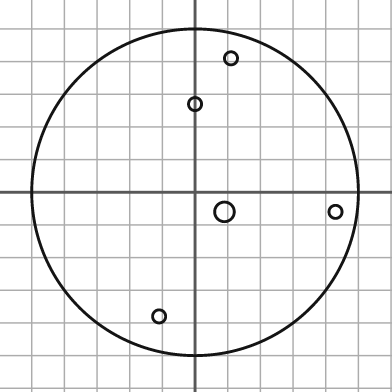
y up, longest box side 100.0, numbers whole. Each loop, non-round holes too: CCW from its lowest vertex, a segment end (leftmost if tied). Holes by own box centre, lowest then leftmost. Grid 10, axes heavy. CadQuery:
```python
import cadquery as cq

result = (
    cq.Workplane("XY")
    .moveTo(0.0, 0.0)
    .circle(50.0)
    .moveTo(-11.0, -38.0)
    .circle(2.0)
    .moveTo(9.0, -6.0)
    .circle(3.0)
    .moveTo(43.0, -6.0)
    .circle(2.0)
    .moveTo(0.0, 27.0)
    .circle(2.0)
    .moveTo(11.0, 41.0)
    .circle(2.0)
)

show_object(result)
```